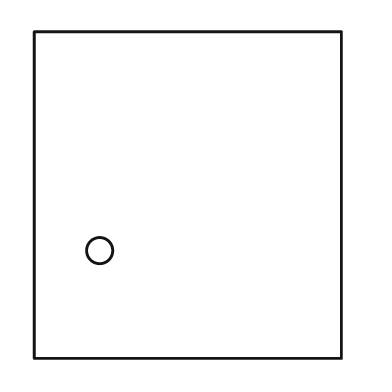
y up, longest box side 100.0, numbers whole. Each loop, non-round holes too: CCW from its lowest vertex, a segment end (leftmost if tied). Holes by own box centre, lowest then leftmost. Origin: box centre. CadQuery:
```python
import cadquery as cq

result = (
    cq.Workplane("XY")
    .moveTo(-47.0, -50.0)
    .lineTo(47.0, -50.0)
    .lineTo(47.0, 50.0)
    .lineTo(-47.0, 50.0)
    .close()
    .moveTo(-27.0, -17.0)
    .circle(4.0)
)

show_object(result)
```